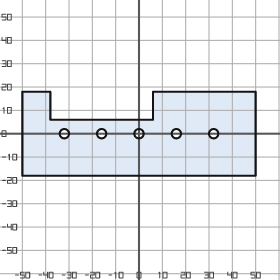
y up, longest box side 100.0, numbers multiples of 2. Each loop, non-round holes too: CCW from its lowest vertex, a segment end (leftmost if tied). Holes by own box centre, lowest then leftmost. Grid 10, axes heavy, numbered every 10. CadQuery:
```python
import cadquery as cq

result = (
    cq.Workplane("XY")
    .moveTo(-50.0, -18.0)
    .lineTo(50.0, -18.0)
    .lineTo(50.0, 18.0)
    .lineTo(6.0, 18.0)
    .lineTo(6.0, 6.0)
    .lineTo(-38.0, 6.0)
    .lineTo(-38.0, 18.0)
    .lineTo(-50.0, 18.0)
    .close()
    .moveTo(-32.0, 0.0)
    .circle(2.0)
    .moveTo(-16.0, 0.0)
    .circle(2.0)
    .moveTo(0.0, 0.0)
    .circle(2.0)
    .moveTo(16.0, 0.0)
    .circle(2.0)
    .moveTo(32.0, 0.0)
    .circle(2.0)
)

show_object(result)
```